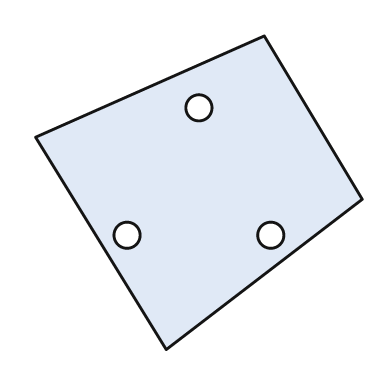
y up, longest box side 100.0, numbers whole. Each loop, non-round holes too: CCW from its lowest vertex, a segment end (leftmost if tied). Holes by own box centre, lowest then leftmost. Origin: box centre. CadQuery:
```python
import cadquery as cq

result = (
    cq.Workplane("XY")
    .moveTo(-10.0, -48.0)
    .lineTo(50.0, -2.0)
    .lineTo(20.0, 48.0)
    .lineTo(-50.0, 17.0)
    .close()
    .moveTo(-22.0, -13.0)
    .circle(4.0)
    .moveTo(22.0, -13.0)
    .circle(4.0)
    .moveTo(0.0, 26.0)
    .circle(4.0)
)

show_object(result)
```